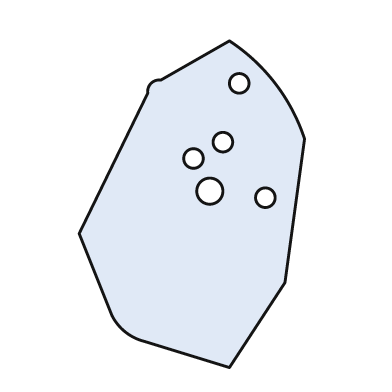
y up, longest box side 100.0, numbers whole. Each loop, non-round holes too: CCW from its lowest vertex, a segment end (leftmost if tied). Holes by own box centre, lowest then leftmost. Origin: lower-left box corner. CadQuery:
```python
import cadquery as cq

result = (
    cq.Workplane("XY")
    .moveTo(46.0, 0.0)
    .lineTo(63.0, 26.0)
    .lineTo(69.0, 70.0)
    .threePointArc((60.0, 87.0), (46.0, 100.0))
    .lineTo(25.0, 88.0)
    .threePointArc((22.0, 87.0), (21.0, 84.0))
    .lineTo(0.0, 41.0)
    .lineTo(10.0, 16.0)
    .threePointArc((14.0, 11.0), (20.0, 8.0))
    .close()
    .moveTo(57.0, 52.0)
    .circle(3.0)
    .moveTo(40.0, 54.0)
    .circle(4.0)
    .moveTo(35.0, 64.0)
    .circle(3.0)
    .moveTo(44.0, 69.0)
    .circle(3.0)
    .moveTo(49.0, 87.0)
    .circle(3.0)
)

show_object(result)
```